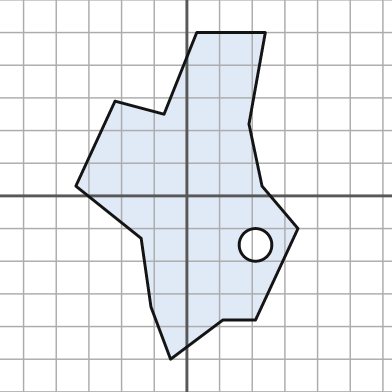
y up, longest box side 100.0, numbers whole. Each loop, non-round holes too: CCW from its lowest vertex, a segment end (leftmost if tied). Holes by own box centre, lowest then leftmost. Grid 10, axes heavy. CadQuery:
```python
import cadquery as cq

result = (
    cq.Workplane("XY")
    .moveTo(-5.0, -50.0)
    .lineTo(11.0, -38.0)
    .lineTo(21.0, -38.0)
    .lineTo(34.0, -10.0)
    .lineTo(23.0, 3.0)
    .lineTo(19.0, 22.0)
    .lineTo(24.0, 50.0)
    .lineTo(3.0, 50.0)
    .lineTo(-7.0, 25.0)
    .lineTo(-22.0, 29.0)
    .lineTo(-34.0, 3.0)
    .lineTo(-14.0, -13.0)
    .lineTo(-11.0, -34.0)
    .close()
    .moveTo(21.0, -15.0)
    .circle(5.0)
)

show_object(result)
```